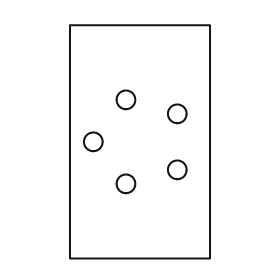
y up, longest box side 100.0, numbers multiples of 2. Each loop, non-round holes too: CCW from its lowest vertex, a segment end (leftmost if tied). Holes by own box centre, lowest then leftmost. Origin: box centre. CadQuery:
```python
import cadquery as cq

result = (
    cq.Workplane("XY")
    .moveTo(-30.0, -50.0)
    .lineTo(30.0, -50.0)
    .lineTo(30.0, 50.0)
    .lineTo(-30.0, 50.0)
    .close()
    .moveTo(-6.0, -18.0)
    .circle(4.0)
    .moveTo(16.0, -12.0)
    .circle(4.0)
    .moveTo(-20.0, 0.0)
    .circle(4.0)
    .moveTo(16.0, 12.0)
    .circle(4.0)
    .moveTo(-6.0, 18.0)
    .circle(4.0)
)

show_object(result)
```